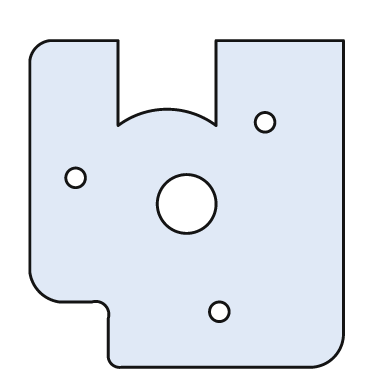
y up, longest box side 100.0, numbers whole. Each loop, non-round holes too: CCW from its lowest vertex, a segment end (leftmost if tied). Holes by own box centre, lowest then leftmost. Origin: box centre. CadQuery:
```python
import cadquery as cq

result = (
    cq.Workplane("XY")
    .moveTo(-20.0, -50.0)
    .lineTo(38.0, -50.0)
    .threePointArc((45.0, -47.0), (48.0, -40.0))
    .lineTo(48.0, 50.0)
    .lineTo(9.0, 50.0)
    .lineTo(9.0, 24.0)
    .threePointArc((-6.0, 29.0), (-21.0, 24.0))
    .lineTo(-21.0, 50.0)
    .lineTo(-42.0, 50.0)
    .threePointArc((-46.0, 48.0), (-48.0, 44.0))
    .lineTo(-48.0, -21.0)
    .threePointArc((-45.0, -27.0), (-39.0, -30.0))
    .lineTo(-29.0, -30.0)
    .threePointArc((-25.0, -31.0), (-24.0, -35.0))
    .lineTo(-24.0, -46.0)
    .threePointArc((-23.0, -49.0), (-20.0, -50.0))
    .close()
    .moveTo(10.0, -33.0)
    .circle(3.0)
    .moveTo(0.0, 0.0)
    .circle(9.0)
    .moveTo(-34.0, 8.0)
    .circle(3.0)
    .moveTo(24.0, 25.0)
    .circle(3.0)
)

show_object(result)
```